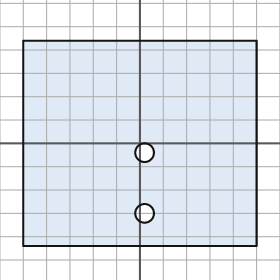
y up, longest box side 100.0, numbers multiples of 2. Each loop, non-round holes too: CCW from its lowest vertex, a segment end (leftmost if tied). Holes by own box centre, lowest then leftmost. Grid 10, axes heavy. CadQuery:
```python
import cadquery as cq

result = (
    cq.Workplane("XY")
    .moveTo(-50.0, -44.0)
    .lineTo(50.0, -44.0)
    .lineTo(50.0, 44.0)
    .lineTo(-50.0, 44.0)
    .close()
    .moveTo(2.0, -30.0)
    .circle(4.0)
    .moveTo(2.0, -4.0)
    .circle(4.0)
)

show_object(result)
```